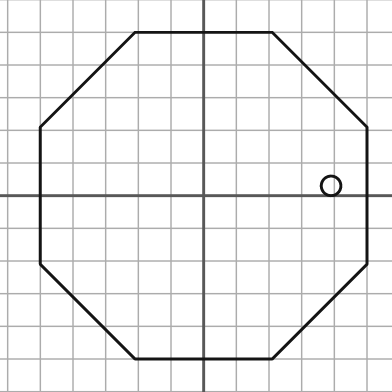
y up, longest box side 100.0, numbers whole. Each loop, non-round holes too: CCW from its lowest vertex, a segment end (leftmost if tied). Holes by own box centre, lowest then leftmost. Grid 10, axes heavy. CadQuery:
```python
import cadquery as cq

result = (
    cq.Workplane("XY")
    .moveTo(-21.0, -50.0)
    .lineTo(21.0, -50.0)
    .lineTo(50.0, -21.0)
    .lineTo(50.0, 21.0)
    .lineTo(21.0, 50.0)
    .lineTo(-21.0, 50.0)
    .lineTo(-50.0, 21.0)
    .lineTo(-50.0, -21.0)
    .close()
    .moveTo(39.0, 3.0)
    .circle(3.0)
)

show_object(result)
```